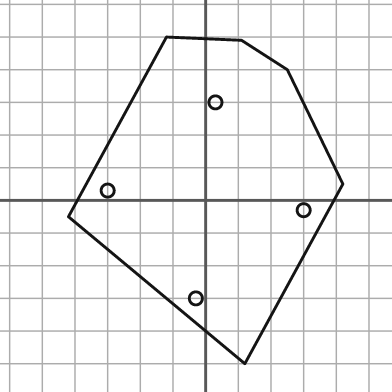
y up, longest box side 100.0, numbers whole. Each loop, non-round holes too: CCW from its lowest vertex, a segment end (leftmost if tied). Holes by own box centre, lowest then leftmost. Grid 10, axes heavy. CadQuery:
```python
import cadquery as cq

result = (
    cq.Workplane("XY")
    .moveTo(12.0, -50.0)
    .lineTo(42.0, 5.0)
    .lineTo(25.0, 40.0)
    .lineTo(11.0, 49.0)
    .lineTo(-12.0, 50.0)
    .lineTo(-42.0, -5.0)
    .close()
    .moveTo(-3.0, -30.0)
    .circle(2.0)
    .moveTo(30.0, -3.0)
    .circle(2.0)
    .moveTo(-30.0, 3.0)
    .circle(2.0)
    .moveTo(3.0, 30.0)
    .circle(2.0)
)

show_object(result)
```